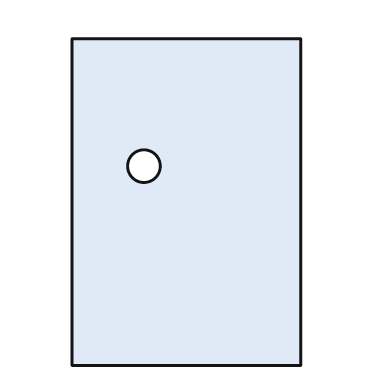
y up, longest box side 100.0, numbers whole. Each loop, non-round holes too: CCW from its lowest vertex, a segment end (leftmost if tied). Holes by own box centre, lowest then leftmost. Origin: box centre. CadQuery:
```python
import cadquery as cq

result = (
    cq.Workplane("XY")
    .moveTo(-35.0, -50.0)
    .lineTo(35.0, -50.0)
    .lineTo(35.0, 50.0)
    .lineTo(-35.0, 50.0)
    .close()
    .moveTo(-13.0, 11.0)
    .circle(5.0)
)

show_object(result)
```